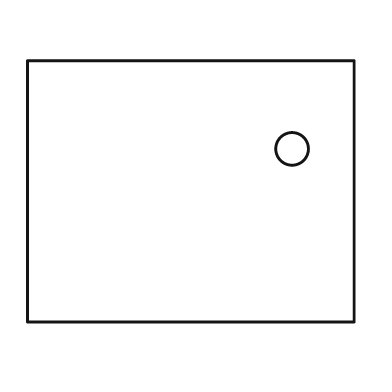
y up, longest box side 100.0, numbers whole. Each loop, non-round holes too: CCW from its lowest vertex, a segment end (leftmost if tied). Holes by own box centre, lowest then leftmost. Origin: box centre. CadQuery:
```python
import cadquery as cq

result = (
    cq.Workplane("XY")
    .moveTo(-50.0, -40.0)
    .lineTo(50.0, -40.0)
    .lineTo(50.0, 40.0)
    .lineTo(-50.0, 40.0)
    .close()
    .moveTo(31.0, 13.0)
    .circle(5.0)
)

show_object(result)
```